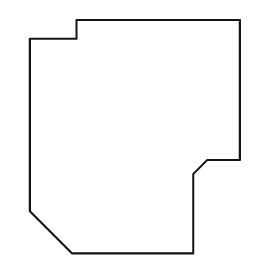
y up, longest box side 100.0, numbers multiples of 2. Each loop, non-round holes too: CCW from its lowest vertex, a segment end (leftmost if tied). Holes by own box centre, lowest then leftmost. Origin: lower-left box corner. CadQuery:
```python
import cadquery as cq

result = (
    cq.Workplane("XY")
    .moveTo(18.0, 0.0)
    .lineTo(70.0, 0.0)
    .lineTo(70.0, 34.0)
    .lineTo(76.0, 40.0)
    .lineTo(90.0, 40.0)
    .lineTo(90.0, 100.0)
    .lineTo(20.0, 100.0)
    .lineTo(20.0, 92.0)
    .lineTo(0.0, 92.0)
    .lineTo(0.0, 18.0)
    .close()
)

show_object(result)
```